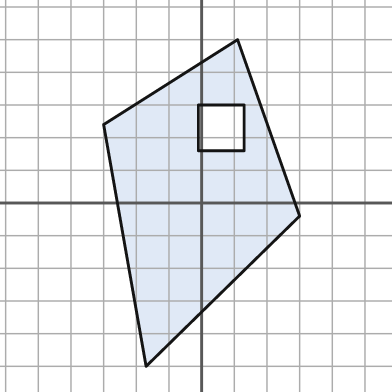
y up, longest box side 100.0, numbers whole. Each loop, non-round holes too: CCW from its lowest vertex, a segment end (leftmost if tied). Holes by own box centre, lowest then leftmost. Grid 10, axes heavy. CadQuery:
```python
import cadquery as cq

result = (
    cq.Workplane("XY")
    .moveTo(-17.0, -50.0)
    .lineTo(30.0, -4.0)
    .lineTo(11.0, 50.0)
    .lineTo(-30.0, 24.0)
    .close()
    .moveTo(-1.0, 16.0)
    .lineTo(13.0, 16.0)
    .lineTo(13.0, 30.0)
    .lineTo(-1.0, 30.0)
    .close()
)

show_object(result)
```